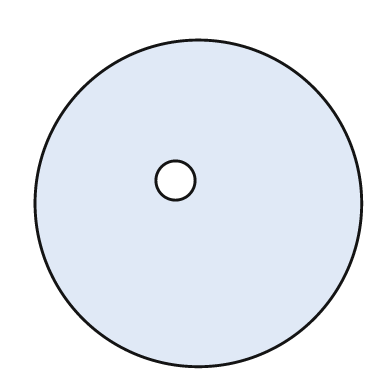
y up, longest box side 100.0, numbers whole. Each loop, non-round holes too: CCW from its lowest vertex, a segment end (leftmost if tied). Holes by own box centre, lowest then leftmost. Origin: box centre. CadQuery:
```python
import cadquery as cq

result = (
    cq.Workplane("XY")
    .moveTo(0.0, 0.0)
    .circle(50.0)
    .moveTo(-7.0, 7.0)
    .circle(6.0)
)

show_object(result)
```